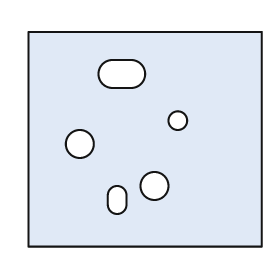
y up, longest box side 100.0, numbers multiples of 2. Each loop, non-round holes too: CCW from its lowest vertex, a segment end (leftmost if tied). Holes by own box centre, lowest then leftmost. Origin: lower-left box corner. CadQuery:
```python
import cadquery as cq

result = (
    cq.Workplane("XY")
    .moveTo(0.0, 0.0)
    .lineTo(100.0, 0.0)
    .lineTo(100.0, 92.0)
    .lineTo(0.0, 92.0)
    .close()
    .moveTo(34.0, 18.0)
    .threePointArc((38.0, 14.0), (42.0, 18.0))
    .lineTo(42.0, 22.0)
    .threePointArc((38.0, 26.0), (34.0, 22.0))
    .close()
    .moveTo(54.0, 26.0)
    .circle(6.0)
    .moveTo(22.0, 44.0)
    .circle(6.0)
    .moveTo(64.0, 54.0)
    .circle(4.0)
    .moveTo(36.0, 68.0)
    .lineTo(44.0, 68.0)
    .threePointArc((50.0, 74.0), (44.0, 80.0))
    .lineTo(36.0, 80.0)
    .threePointArc((30.0, 74.0), (36.0, 68.0))
    .close()
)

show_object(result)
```